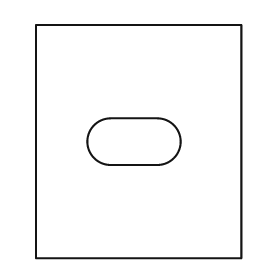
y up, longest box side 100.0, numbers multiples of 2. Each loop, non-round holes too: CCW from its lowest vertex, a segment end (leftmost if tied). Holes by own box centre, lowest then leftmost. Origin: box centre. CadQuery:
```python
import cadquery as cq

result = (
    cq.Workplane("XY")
    .moveTo(-44.0, -50.0)
    .lineTo(44.0, -50.0)
    .lineTo(44.0, 50.0)
    .lineTo(-44.0, 50.0)
    .close()
    .moveTo(-12.0, -10.0)
    .lineTo(8.0, -10.0)
    .threePointArc((18.0, 0.0), (8.0, 10.0))
    .lineTo(-12.0, 10.0)
    .threePointArc((-22.0, 0.0), (-12.0, -10.0))
    .close()
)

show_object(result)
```